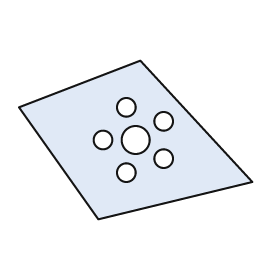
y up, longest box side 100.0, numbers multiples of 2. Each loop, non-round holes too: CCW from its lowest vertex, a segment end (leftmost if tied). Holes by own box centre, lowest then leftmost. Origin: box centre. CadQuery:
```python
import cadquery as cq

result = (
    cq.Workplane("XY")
    .moveTo(-16.0, -34.0)
    .lineTo(50.0, -18.0)
    .lineTo(2.0, 34.0)
    .lineTo(-50.0, 14.0)
    .close()
    .moveTo(-4.0, -14.0)
    .circle(4.0)
    .moveTo(12.0, -8.0)
    .circle(4.0)
    .moveTo(-14.0, 0.0)
    .circle(4.0)
    .moveTo(0.0, 0.0)
    .circle(6.0)
    .moveTo(12.0, 8.0)
    .circle(4.0)
    .moveTo(-4.0, 14.0)
    .circle(4.0)
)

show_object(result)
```